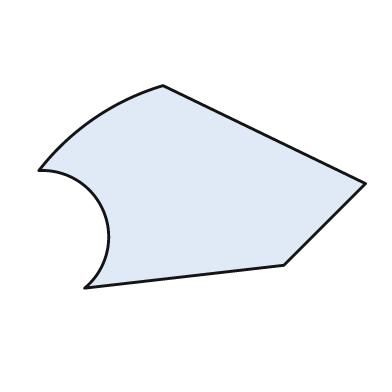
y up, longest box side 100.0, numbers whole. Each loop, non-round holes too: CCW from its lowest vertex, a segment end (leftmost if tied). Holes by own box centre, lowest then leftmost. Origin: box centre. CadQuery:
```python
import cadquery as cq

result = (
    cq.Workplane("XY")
    .moveTo(-36.0, -31.0)
    .lineTo(25.0, -24.0)
    .lineTo(50.0, 1.0)
    .lineTo(-12.0, 31.0)
    .threePointArc((-33.0, 21.0), (-50.0, 5.0))
    .threePointArc((-30.0, -8.0), (-36.0, -31.0))
    .close()
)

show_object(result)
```